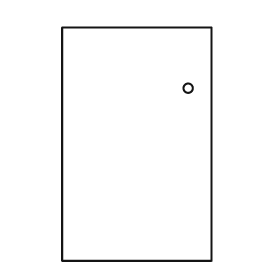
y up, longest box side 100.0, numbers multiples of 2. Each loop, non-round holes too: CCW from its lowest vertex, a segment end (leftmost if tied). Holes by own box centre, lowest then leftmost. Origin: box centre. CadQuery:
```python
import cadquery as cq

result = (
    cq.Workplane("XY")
    .moveTo(-32.0, -50.0)
    .lineTo(32.0, -50.0)
    .lineTo(32.0, 50.0)
    .lineTo(-32.0, 50.0)
    .close()
    .moveTo(22.0, 24.0)
    .circle(2.0)
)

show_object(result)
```